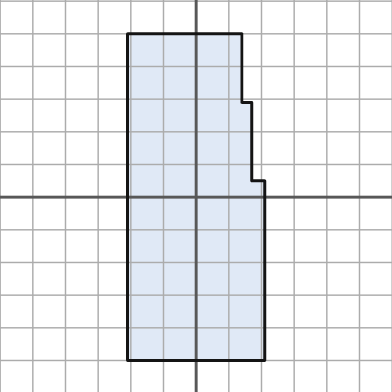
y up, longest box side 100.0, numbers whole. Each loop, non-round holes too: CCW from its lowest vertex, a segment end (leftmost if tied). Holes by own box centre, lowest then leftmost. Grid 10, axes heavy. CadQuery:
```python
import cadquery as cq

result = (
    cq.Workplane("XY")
    .moveTo(-21.0, -50.0)
    .lineTo(21.0, -50.0)
    .lineTo(21.0, 5.0)
    .lineTo(17.0, 5.0)
    .lineTo(17.0, 29.0)
    .lineTo(14.0, 29.0)
    .lineTo(14.0, 50.0)
    .lineTo(-21.0, 50.0)
    .close()
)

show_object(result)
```